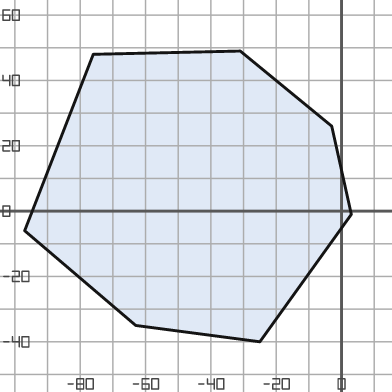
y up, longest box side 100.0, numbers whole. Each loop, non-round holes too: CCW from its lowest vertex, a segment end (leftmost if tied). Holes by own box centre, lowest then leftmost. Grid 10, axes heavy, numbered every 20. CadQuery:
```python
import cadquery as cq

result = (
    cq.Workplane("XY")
    .moveTo(-25.0, -40.0)
    .lineTo(3.0, -1.0)
    .lineTo(-3.0, 26.0)
    .lineTo(-31.0, 49.0)
    .lineTo(-76.0, 48.0)
    .lineTo(-97.0, -6.0)
    .lineTo(-63.0, -35.0)
    .close()
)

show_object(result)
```